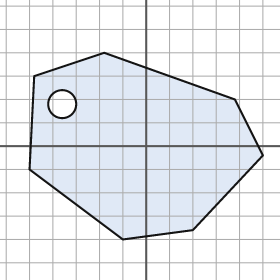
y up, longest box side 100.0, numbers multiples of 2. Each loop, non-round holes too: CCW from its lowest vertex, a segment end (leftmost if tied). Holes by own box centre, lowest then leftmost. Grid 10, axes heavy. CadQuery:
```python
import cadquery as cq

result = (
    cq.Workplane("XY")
    .moveTo(-10.0, -40.0)
    .lineTo(20.0, -36.0)
    .lineTo(50.0, -4.0)
    .lineTo(38.0, 20.0)
    .lineTo(-18.0, 40.0)
    .lineTo(-48.0, 30.0)
    .lineTo(-50.0, -10.0)
    .close()
    .moveTo(-36.0, 18.0)
    .circle(6.0)
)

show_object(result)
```